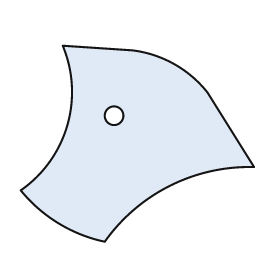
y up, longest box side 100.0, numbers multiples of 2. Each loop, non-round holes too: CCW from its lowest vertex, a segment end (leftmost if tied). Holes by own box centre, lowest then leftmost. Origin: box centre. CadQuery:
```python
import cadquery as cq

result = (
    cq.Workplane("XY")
    .moveTo(-14.0, -42.0)
    .threePointArc((14.0, -18.0), (50.0, -10.0))
    .lineTo(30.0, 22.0)
    .threePointArc((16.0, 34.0), (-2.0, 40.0))
    .lineTo(-32.0, 42.0)
    .threePointArc((-30.0, 8.0), (-50.0, -20.0))
    .threePointArc((-34.0, -34.0), (-14.0, -42.0))
    .close()
    .moveTo(-10.0, 12.0)
    .circle(4.0)
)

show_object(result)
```